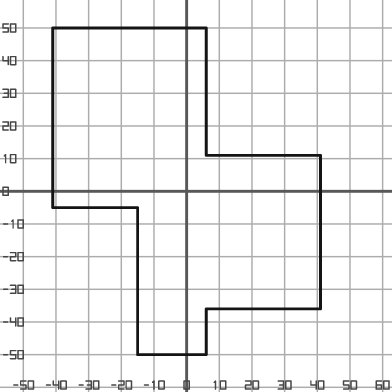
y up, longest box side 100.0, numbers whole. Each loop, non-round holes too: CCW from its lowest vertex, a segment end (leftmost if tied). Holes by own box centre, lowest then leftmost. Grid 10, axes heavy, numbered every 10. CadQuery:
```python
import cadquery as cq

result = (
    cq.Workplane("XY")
    .moveTo(-15.0, -50.0)
    .lineTo(6.0, -50.0)
    .lineTo(6.0, -36.0)
    .lineTo(41.0, -36.0)
    .lineTo(41.0, 11.0)
    .lineTo(6.0, 11.0)
    .lineTo(6.0, 50.0)
    .lineTo(-41.0, 50.0)
    .lineTo(-41.0, -5.0)
    .lineTo(-15.0, -5.0)
    .close()
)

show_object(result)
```